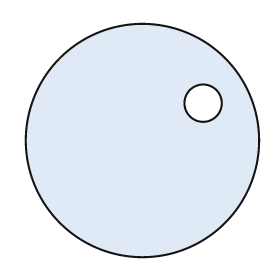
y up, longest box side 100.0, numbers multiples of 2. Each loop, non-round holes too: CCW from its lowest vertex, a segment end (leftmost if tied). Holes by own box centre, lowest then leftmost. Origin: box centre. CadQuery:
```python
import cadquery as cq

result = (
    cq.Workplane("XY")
    .moveTo(0.0, 0.0)
    .circle(50.0)
    .moveTo(26.0, 16.0)
    .circle(8.0)
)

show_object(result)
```